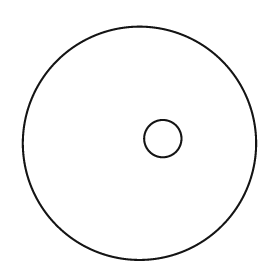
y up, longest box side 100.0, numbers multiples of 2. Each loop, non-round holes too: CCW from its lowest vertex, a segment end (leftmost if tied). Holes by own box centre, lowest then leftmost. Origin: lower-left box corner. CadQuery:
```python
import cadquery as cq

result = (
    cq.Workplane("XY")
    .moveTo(50.0, 50.0)
    .circle(50.0)
    .moveTo(60.0, 52.0)
    .circle(8.0)
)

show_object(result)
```